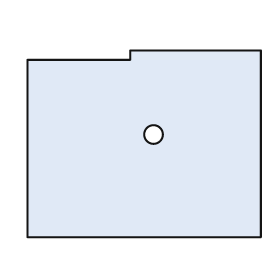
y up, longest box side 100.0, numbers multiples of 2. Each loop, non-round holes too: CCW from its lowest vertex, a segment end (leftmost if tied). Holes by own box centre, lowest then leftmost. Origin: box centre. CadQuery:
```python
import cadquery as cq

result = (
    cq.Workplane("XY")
    .moveTo(-50.0, -40.0)
    .lineTo(50.0, -40.0)
    .lineTo(50.0, 40.0)
    .lineTo(-6.0, 40.0)
    .lineTo(-6.0, 36.0)
    .lineTo(-50.0, 36.0)
    .close()
    .moveTo(4.0, 4.0)
    .circle(4.0)
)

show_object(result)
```